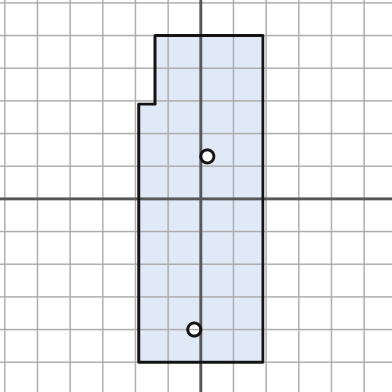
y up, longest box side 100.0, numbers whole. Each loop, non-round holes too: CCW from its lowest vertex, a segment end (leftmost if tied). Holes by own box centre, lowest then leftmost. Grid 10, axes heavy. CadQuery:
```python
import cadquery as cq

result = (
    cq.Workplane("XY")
    .moveTo(-19.0, -50.0)
    .lineTo(19.0, -50.0)
    .lineTo(19.0, 50.0)
    .lineTo(-14.0, 50.0)
    .lineTo(-14.0, 29.0)
    .lineTo(-19.0, 29.0)
    .close()
    .moveTo(-2.0, -40.0)
    .circle(2.0)
    .moveTo(2.0, 13.0)
    .circle(2.0)
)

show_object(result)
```